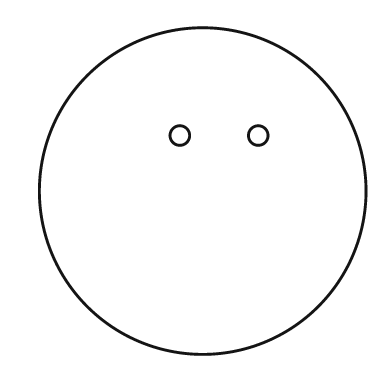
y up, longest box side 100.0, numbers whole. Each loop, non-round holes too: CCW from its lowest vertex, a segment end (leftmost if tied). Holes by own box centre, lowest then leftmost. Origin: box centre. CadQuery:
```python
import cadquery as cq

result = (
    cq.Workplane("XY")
    .moveTo(0.0, 0.0)
    .circle(50.0)
    .moveTo(-7.0, 17.0)
    .circle(3.0)
    .moveTo(17.0, 17.0)
    .circle(3.0)
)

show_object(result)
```